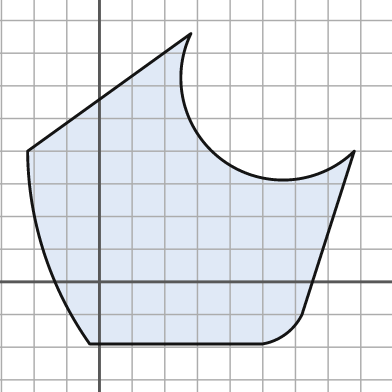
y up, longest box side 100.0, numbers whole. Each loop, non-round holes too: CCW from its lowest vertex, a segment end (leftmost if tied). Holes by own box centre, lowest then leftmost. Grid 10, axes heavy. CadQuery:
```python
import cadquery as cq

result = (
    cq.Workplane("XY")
    .moveTo(-3.0, -19.0)
    .lineTo(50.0, -19.0)
    .threePointArc((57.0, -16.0), (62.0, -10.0))
    .lineTo(78.0, 40.0)
    .threePointArc((38.0, 37.0), (28.0, 76.0))
    .lineTo(-22.0, 40.0)
    .threePointArc((-17.0, 9.0), (-3.0, -19.0))
    .close()
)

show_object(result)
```